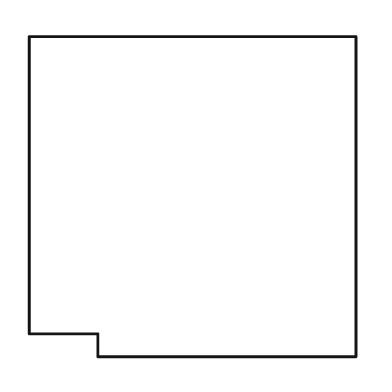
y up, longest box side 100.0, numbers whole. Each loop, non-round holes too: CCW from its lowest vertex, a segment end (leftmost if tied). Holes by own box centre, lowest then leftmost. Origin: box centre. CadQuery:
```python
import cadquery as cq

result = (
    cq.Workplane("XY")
    .moveTo(-29.0, -49.0)
    .lineTo(50.0, -49.0)
    .lineTo(50.0, 49.0)
    .lineTo(-50.0, 49.0)
    .lineTo(-50.0, -42.0)
    .lineTo(-29.0, -42.0)
    .close()
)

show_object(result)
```